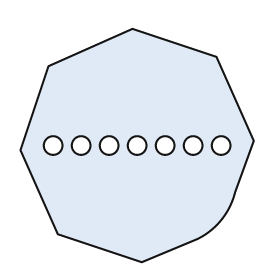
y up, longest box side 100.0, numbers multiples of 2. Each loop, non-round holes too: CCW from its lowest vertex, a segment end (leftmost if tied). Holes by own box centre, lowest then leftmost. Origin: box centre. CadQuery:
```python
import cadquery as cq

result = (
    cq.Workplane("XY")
    .moveTo(2.0, -50.0)
    .lineTo(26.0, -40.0)
    .threePointArc((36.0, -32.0), (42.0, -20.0))
    .lineTo(50.0, 2.0)
    .lineTo(34.0, 38.0)
    .lineTo(-2.0, 50.0)
    .lineTo(-38.0, 34.0)
    .lineTo(-50.0, -2.0)
    .lineTo(-34.0, -38.0)
    .close()
    .moveTo(-36.0, 0.0)
    .circle(4.0)
    .moveTo(-24.0, 0.0)
    .circle(4.0)
    .moveTo(-12.0, 0.0)
    .circle(4.0)
    .moveTo(0.0, 0.0)
    .circle(4.0)
    .moveTo(12.0, 0.0)
    .circle(4.0)
    .moveTo(24.0, 0.0)
    .circle(4.0)
    .moveTo(36.0, 0.0)
    .circle(4.0)
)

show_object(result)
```